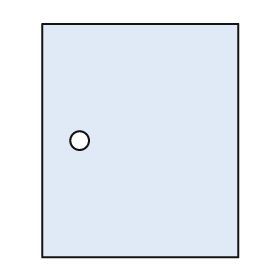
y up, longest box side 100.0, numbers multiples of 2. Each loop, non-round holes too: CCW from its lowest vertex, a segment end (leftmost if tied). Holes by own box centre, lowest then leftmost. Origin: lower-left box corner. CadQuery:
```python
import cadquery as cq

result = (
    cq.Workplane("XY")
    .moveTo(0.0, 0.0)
    .lineTo(84.0, 0.0)
    .lineTo(84.0, 100.0)
    .lineTo(0.0, 100.0)
    .close()
    .moveTo(16.0, 50.0)
    .circle(4.0)
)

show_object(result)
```